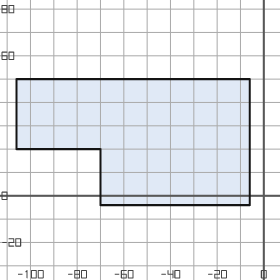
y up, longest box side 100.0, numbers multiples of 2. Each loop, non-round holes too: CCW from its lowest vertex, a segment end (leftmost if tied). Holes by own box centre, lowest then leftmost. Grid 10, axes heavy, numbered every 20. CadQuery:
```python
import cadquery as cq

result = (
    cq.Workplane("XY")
    .moveTo(-70.0, -4.0)
    .lineTo(-6.0, -4.0)
    .lineTo(-6.0, 50.0)
    .lineTo(-106.0, 50.0)
    .lineTo(-106.0, 20.0)
    .lineTo(-70.0, 20.0)
    .close()
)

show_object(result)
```